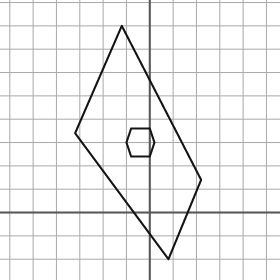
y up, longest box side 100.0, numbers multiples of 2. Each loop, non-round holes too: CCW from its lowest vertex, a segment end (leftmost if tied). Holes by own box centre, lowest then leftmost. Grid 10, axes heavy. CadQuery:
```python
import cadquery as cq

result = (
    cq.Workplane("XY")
    .moveTo(8.0, -20.0)
    .lineTo(22.0, 14.0)
    .lineTo(-12.0, 80.0)
    .lineTo(-32.0, 34.0)
    .close()
    .moveTo(-8.0, 24.0)
    .lineTo(0.0, 24.0)
    .lineTo(2.0, 30.0)
    .lineTo(0.0, 36.0)
    .lineTo(-8.0, 36.0)
    .lineTo(-10.0, 30.0)
    .close()
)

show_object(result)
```